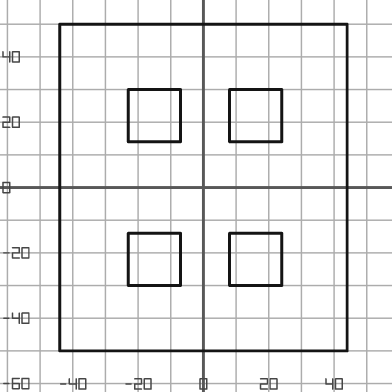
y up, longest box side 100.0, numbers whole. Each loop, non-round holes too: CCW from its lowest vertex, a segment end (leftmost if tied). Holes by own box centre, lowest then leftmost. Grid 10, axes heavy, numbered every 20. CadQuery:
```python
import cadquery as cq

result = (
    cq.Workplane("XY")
    .moveTo(-44.0, -50.0)
    .lineTo(44.0, -50.0)
    .lineTo(44.0, 50.0)
    .lineTo(-44.0, 50.0)
    .close()
    .moveTo(-23.0, -30.0)
    .lineTo(-7.0, -30.0)
    .lineTo(-7.0, -14.0)
    .lineTo(-23.0, -14.0)
    .close()
    .moveTo(8.0, -30.0)
    .lineTo(24.0, -30.0)
    .lineTo(24.0, -14.0)
    .lineTo(8.0, -14.0)
    .close()
    .moveTo(-23.0, 14.0)
    .lineTo(-7.0, 14.0)
    .lineTo(-7.0, 30.0)
    .lineTo(-23.0, 30.0)
    .close()
    .moveTo(8.0, 14.0)
    .lineTo(24.0, 14.0)
    .lineTo(24.0, 30.0)
    .lineTo(8.0, 30.0)
    .close()
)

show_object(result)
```